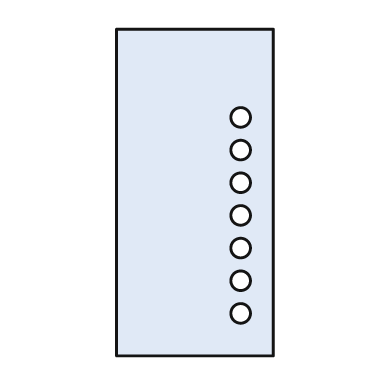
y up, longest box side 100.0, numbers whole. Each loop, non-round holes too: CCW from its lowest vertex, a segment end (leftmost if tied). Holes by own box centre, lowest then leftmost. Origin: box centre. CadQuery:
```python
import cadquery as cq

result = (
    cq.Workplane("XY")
    .moveTo(-24.0, -50.0)
    .lineTo(24.0, -50.0)
    .lineTo(24.0, 50.0)
    .lineTo(-24.0, 50.0)
    .close()
    .moveTo(14.0, -37.0)
    .circle(3.0)
    .moveTo(14.0, -27.0)
    .circle(3.0)
    .moveTo(14.0, -17.0)
    .circle(3.0)
    .moveTo(14.0, -7.0)
    .circle(3.0)
    .moveTo(14.0, 3.0)
    .circle(3.0)
    .moveTo(14.0, 13.0)
    .circle(3.0)
    .moveTo(14.0, 23.0)
    .circle(3.0)
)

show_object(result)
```